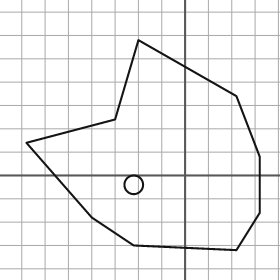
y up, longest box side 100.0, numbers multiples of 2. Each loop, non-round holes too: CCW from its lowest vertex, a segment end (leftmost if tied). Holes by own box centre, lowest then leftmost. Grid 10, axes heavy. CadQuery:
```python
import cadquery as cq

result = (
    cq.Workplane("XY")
    .moveTo(22.0, -32.0)
    .lineTo(32.0, -16.0)
    .lineTo(32.0, 8.0)
    .lineTo(22.0, 34.0)
    .lineTo(-20.0, 58.0)
    .lineTo(-30.0, 24.0)
    .lineTo(-68.0, 14.0)
    .lineTo(-40.0, -18.0)
    .lineTo(-22.0, -30.0)
    .close()
    .moveTo(-22.0, -4.0)
    .circle(4.0)
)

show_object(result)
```